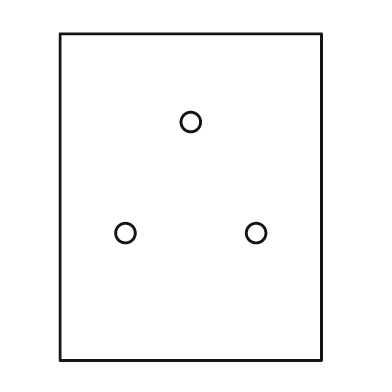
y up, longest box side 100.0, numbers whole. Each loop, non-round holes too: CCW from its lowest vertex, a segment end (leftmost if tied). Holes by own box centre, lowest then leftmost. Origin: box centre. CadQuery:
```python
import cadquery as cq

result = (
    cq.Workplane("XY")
    .moveTo(-40.0, -50.0)
    .lineTo(40.0, -50.0)
    .lineTo(40.0, 50.0)
    .lineTo(-40.0, 50.0)
    .close()
    .moveTo(-20.0, -11.0)
    .circle(3.0)
    .moveTo(20.0, -11.0)
    .circle(3.0)
    .moveTo(0.0, 23.0)
    .circle(3.0)
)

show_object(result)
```